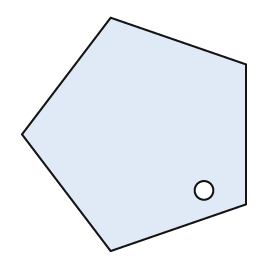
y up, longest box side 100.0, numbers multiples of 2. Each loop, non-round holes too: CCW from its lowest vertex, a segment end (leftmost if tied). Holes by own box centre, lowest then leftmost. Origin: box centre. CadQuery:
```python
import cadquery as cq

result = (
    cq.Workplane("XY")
    .moveTo(-10.0, -50.0)
    .lineTo(48.0, -30.0)
    .lineTo(48.0, 30.0)
    .lineTo(-10.0, 50.0)
    .lineTo(-48.0, 0.0)
    .close()
    .moveTo(30.0, -24.0)
    .circle(4.0)
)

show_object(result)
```